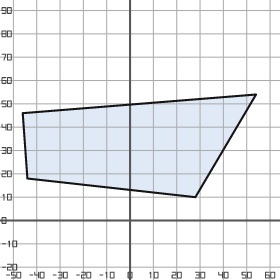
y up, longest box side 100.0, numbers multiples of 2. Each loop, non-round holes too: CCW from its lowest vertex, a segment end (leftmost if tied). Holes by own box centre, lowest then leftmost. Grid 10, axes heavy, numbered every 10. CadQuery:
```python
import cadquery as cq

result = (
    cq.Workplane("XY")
    .moveTo(28.0, 10.0)
    .lineTo(54.0, 54.0)
    .lineTo(-46.0, 46.0)
    .lineTo(-44.0, 18.0)
    .close()
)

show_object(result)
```